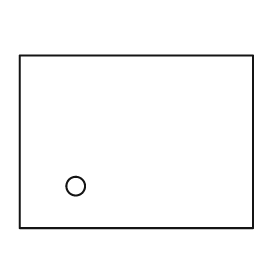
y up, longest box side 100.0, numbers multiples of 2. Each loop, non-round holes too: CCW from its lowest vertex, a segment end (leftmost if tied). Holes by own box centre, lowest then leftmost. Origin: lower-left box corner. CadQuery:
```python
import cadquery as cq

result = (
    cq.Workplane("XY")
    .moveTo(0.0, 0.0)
    .lineTo(100.0, 0.0)
    .lineTo(100.0, 74.0)
    .lineTo(0.0, 74.0)
    .close()
    .moveTo(24.0, 18.0)
    .circle(4.0)
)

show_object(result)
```